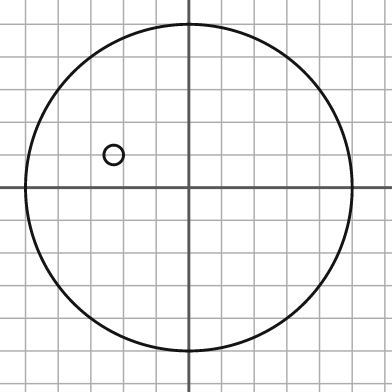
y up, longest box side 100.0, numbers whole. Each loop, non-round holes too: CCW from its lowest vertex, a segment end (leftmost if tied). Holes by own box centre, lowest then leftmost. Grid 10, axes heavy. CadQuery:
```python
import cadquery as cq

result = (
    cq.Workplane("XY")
    .moveTo(0.0, 0.0)
    .circle(50.0)
    .moveTo(-23.0, 10.0)
    .circle(3.0)
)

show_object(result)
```